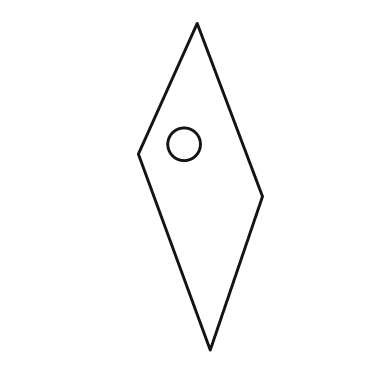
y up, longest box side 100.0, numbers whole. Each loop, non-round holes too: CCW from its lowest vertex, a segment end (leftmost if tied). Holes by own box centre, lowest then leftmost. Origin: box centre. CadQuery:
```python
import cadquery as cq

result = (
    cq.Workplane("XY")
    .moveTo(3.0, -50.0)
    .lineTo(19.0, -3.0)
    .lineTo(-1.0, 50.0)
    .lineTo(-19.0, 10.0)
    .close()
    .moveTo(-5.0, 13.0)
    .circle(5.0)
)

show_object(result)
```